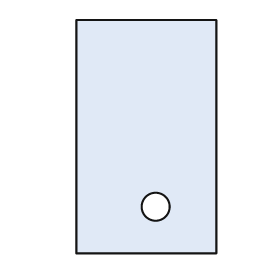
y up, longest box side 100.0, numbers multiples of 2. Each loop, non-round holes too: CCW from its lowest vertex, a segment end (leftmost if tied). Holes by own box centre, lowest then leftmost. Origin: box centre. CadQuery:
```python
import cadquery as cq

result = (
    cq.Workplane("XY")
    .moveTo(-30.0, -50.0)
    .lineTo(30.0, -50.0)
    .lineTo(30.0, 50.0)
    .lineTo(-30.0, 50.0)
    .close()
    .moveTo(4.0, -30.0)
    .circle(6.0)
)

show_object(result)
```